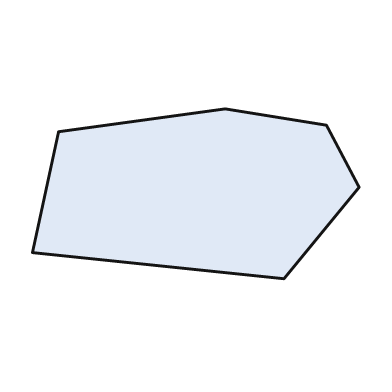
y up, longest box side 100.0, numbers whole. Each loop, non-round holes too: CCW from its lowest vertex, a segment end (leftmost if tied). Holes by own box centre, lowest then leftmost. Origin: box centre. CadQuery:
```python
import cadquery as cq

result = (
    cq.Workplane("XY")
    .moveTo(27.0, -26.0)
    .lineTo(50.0, 2.0)
    .lineTo(40.0, 21.0)
    .lineTo(9.0, 26.0)
    .lineTo(-42.0, 19.0)
    .lineTo(-50.0, -18.0)
    .close()
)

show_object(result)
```